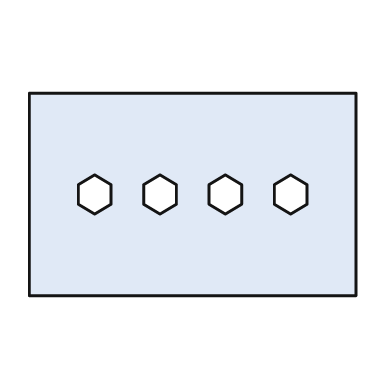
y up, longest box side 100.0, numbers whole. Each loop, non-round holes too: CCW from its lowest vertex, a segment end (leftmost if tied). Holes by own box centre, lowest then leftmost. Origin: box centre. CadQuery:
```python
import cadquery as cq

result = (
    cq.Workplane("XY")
    .moveTo(-50.0, -31.0)
    .lineTo(50.0, -31.0)
    .lineTo(50.0, 31.0)
    .lineTo(-50.0, 31.0)
    .close()
    .moveTo(-30.0, -6.0)
    .lineTo(-25.0, -3.0)
    .lineTo(-25.0, 3.0)
    .lineTo(-30.0, 6.0)
    .lineTo(-35.0, 3.0)
    .lineTo(-35.0, -3.0)
    .close()
    .moveTo(-10.0, -6.0)
    .lineTo(-5.0, -3.0)
    .lineTo(-5.0, 3.0)
    .lineTo(-10.0, 6.0)
    .lineTo(-15.0, 3.0)
    .lineTo(-15.0, -3.0)
    .close()
    .moveTo(10.0, -6.0)
    .lineTo(15.0, -3.0)
    .lineTo(15.0, 3.0)
    .lineTo(10.0, 6.0)
    .lineTo(5.0, 3.0)
    .lineTo(5.0, -3.0)
    .close()
    .moveTo(30.0, -6.0)
    .lineTo(35.0, -3.0)
    .lineTo(35.0, 3.0)
    .lineTo(30.0, 6.0)
    .lineTo(25.0, 3.0)
    .lineTo(25.0, -3.0)
    .close()
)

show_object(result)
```